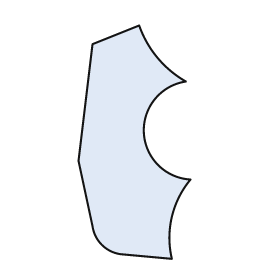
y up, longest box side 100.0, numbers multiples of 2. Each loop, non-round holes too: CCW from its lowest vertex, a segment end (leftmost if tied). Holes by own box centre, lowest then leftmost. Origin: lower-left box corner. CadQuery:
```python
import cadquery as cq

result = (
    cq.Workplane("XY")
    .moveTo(40.0, 0.0)
    .threePointArc((40.0, 18.0), (48.0, 34.0))
    .threePointArc((28.0, 54.0), (46.0, 76.0))
    .threePointArc((34.0, 86.0), (26.0, 100.0))
    .lineTo(6.0, 92.0)
    .lineTo(0.0, 42.0)
    .lineTo(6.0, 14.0)
    .threePointArc((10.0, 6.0), (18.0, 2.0))
    .close()
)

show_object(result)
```